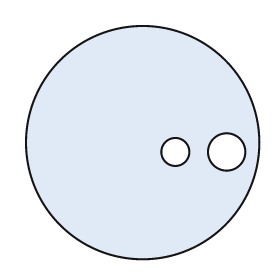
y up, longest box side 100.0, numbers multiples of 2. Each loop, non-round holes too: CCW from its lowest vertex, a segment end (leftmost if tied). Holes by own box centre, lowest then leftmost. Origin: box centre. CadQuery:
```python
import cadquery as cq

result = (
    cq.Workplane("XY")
    .moveTo(0.0, 0.0)
    .circle(50.0)
    .moveTo(14.0, -4.0)
    .circle(6.0)
    .moveTo(36.0, -4.0)
    .circle(8.0)
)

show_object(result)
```